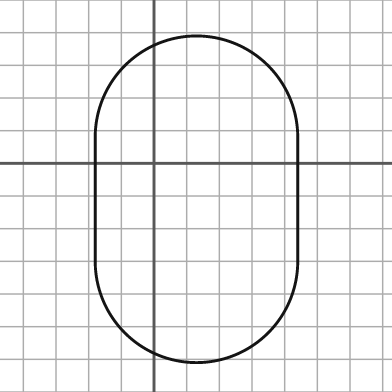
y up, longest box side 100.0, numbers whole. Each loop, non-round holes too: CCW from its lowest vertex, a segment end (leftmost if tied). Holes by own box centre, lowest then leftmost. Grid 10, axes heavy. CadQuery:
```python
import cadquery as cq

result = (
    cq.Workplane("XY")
    .moveTo(-18.0, -30.0)
    .threePointArc((13.0, -61.0), (44.0, -30.0))
    .lineTo(44.0, 8.0)
    .threePointArc((13.0, 39.0), (-18.0, 8.0))
    .close()
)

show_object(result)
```